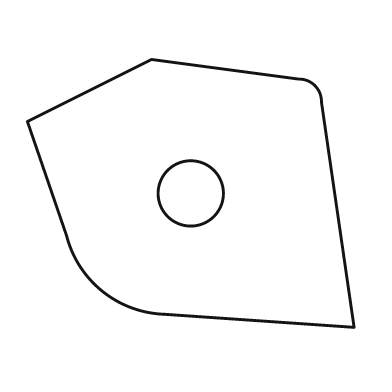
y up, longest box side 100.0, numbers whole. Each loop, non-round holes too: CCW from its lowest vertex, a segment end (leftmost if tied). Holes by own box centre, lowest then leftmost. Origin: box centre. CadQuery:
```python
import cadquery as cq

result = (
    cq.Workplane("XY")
    .moveTo(50.0, -41.0)
    .lineTo(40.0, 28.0)
    .threePointArc((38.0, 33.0), (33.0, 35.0))
    .lineTo(-12.0, 41.0)
    .lineTo(-50.0, 22.0)
    .lineTo(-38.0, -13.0)
    .threePointArc((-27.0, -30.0), (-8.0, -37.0))
    .close()
    .moveTo(0.0, 0.0)
    .circle(10.0)
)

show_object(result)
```